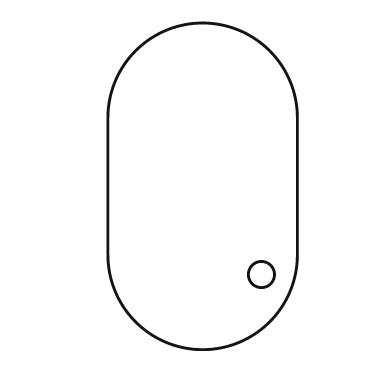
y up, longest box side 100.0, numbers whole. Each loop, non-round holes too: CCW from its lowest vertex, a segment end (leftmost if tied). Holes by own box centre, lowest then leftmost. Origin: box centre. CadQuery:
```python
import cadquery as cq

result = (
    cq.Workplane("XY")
    .moveTo(-29.0, -21.0)
    .threePointArc((0.0, -50.0), (29.0, -21.0))
    .lineTo(29.0, 21.0)
    .threePointArc((0.0, 50.0), (-29.0, 21.0))
    .close()
    .moveTo(18.0, -27.0)
    .circle(4.0)
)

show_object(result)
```